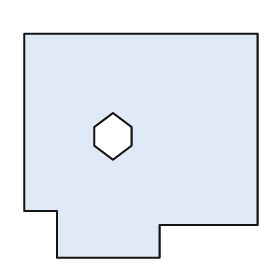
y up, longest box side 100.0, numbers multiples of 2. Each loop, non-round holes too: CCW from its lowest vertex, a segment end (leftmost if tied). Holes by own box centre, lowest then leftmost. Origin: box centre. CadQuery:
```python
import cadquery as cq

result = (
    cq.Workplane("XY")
    .moveTo(-36.0, -48.0)
    .lineTo(8.0, -48.0)
    .lineTo(8.0, -34.0)
    .lineTo(50.0, -34.0)
    .lineTo(50.0, 48.0)
    .lineTo(-50.0, 48.0)
    .lineTo(-50.0, -28.0)
    .lineTo(-36.0, -28.0)
    .close()
    .moveTo(-12.0, -6.0)
    .lineTo(-4.0, 0.0)
    .lineTo(-4.0, 8.0)
    .lineTo(-12.0, 14.0)
    .lineTo(-20.0, 8.0)
    .lineTo(-20.0, 0.0)
    .close()
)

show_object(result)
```